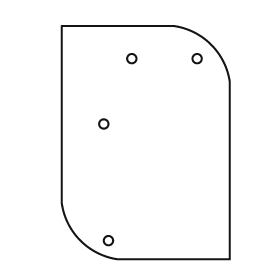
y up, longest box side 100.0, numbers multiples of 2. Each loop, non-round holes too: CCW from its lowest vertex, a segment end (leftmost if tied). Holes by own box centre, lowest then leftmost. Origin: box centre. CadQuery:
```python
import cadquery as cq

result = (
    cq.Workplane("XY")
    .moveTo(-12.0, -50.0)
    .lineTo(36.0, -50.0)
    .lineTo(36.0, 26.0)
    .threePointArc((28.0, 42.0), (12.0, 50.0))
    .lineTo(-36.0, 50.0)
    .lineTo(-36.0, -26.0)
    .threePointArc((-28.0, -42.0), (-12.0, -50.0))
    .close()
    .moveTo(-16.0, -42.0)
    .circle(2.0)
    .moveTo(-18.0, 8.0)
    .circle(2.0)
    .moveTo(-6.0, 36.0)
    .circle(2.0)
    .moveTo(22.0, 36.0)
    .circle(2.0)
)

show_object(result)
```